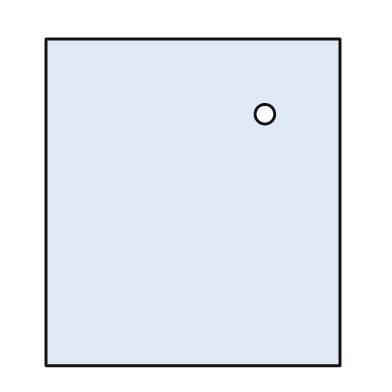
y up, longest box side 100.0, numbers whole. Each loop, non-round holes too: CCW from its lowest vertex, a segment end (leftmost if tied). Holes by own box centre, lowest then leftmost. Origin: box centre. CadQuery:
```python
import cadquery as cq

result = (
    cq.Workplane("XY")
    .moveTo(-45.0, -50.0)
    .lineTo(45.0, -50.0)
    .lineTo(45.0, 50.0)
    .lineTo(-45.0, 50.0)
    .close()
    .moveTo(22.0, 27.0)
    .circle(3.0)
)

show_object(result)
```